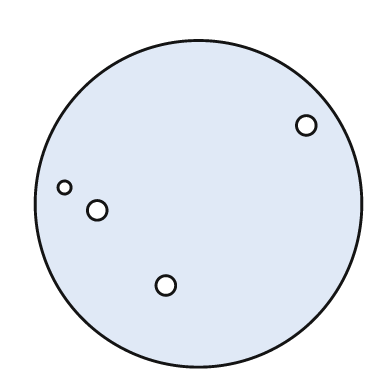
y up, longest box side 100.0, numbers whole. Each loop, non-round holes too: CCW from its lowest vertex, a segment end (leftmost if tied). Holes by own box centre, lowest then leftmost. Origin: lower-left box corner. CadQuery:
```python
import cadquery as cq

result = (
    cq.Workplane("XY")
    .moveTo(50.0, 50.0)
    .circle(50.0)
    .moveTo(40.0, 25.0)
    .circle(3.0)
    .moveTo(19.0, 48.0)
    .circle(3.0)
    .moveTo(9.0, 55.0)
    .circle(2.0)
    .moveTo(83.0, 74.0)
    .circle(3.0)
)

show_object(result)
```